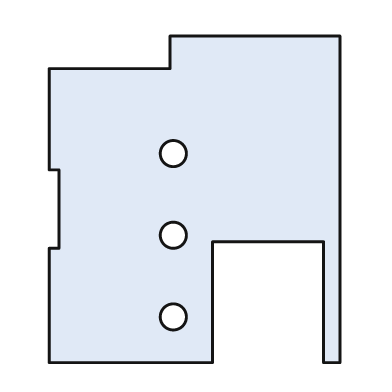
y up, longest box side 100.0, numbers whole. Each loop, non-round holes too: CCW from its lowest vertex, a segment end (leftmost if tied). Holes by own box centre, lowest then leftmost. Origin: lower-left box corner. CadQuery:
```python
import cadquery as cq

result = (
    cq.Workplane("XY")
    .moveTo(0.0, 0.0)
    .lineTo(50.0, 0.0)
    .lineTo(50.0, 37.0)
    .lineTo(84.0, 37.0)
    .lineTo(84.0, 0.0)
    .lineTo(89.0, 0.0)
    .lineTo(89.0, 100.0)
    .lineTo(37.0, 100.0)
    .lineTo(37.0, 90.0)
    .lineTo(0.0, 90.0)
    .lineTo(0.0, 59.0)
    .lineTo(3.0, 59.0)
    .lineTo(3.0, 35.0)
    .lineTo(0.0, 35.0)
    .close()
    .moveTo(38.0, 14.0)
    .circle(4.0)
    .moveTo(38.0, 39.0)
    .circle(4.0)
    .moveTo(38.0, 64.0)
    .circle(4.0)
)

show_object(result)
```